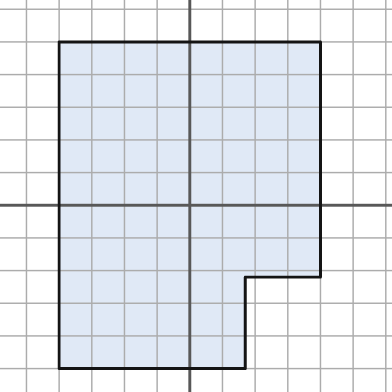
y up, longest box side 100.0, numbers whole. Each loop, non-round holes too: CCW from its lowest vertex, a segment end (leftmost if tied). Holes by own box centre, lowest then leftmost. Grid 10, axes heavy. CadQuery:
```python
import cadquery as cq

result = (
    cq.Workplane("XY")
    .moveTo(-40.0, -50.0)
    .lineTo(17.0, -50.0)
    .lineTo(17.0, -22.0)
    .lineTo(40.0, -22.0)
    .lineTo(40.0, 50.0)
    .lineTo(-40.0, 50.0)
    .close()
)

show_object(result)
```